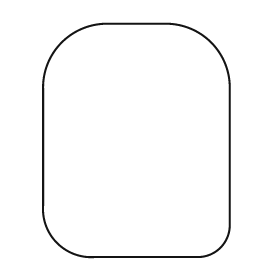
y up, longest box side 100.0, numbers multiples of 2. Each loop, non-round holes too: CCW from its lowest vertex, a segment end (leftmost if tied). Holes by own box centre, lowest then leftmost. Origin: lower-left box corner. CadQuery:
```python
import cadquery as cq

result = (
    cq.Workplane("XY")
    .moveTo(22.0, 0.0)
    .lineTo(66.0, 0.0)
    .threePointArc((76.0, 4.0), (80.0, 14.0))
    .lineTo(80.0, 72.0)
    .threePointArc((72.0, 92.0), (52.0, 100.0))
    .lineTo(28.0, 100.0)
    .threePointArc((8.0, 92.0), (0.0, 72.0))
    .lineTo(0.0, 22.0)
    .threePointArc((6.0, 6.0), (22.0, 0.0))
    .close()
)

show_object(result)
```